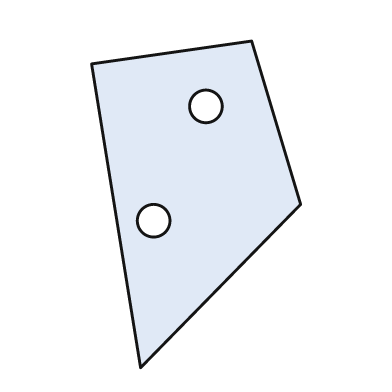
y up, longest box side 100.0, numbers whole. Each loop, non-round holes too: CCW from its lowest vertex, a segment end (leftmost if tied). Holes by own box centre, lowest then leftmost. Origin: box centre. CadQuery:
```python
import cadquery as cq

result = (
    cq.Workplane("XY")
    .moveTo(-17.0, -50.0)
    .lineTo(32.0, 0.0)
    .lineTo(17.0, 50.0)
    .lineTo(-32.0, 43.0)
    .close()
    .moveTo(-13.0, -5.0)
    .circle(5.0)
    .moveTo(3.0, 30.0)
    .circle(5.0)
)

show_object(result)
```